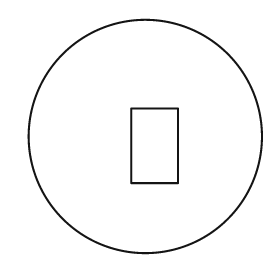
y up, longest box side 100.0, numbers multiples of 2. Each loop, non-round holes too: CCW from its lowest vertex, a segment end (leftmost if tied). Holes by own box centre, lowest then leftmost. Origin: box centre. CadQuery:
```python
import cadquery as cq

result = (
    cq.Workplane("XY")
    .moveTo(0.0, 0.0)
    .circle(50.0)
    .moveTo(-6.0, -20.0)
    .lineTo(14.0, -20.0)
    .lineTo(14.0, 12.0)
    .lineTo(-6.0, 12.0)
    .close()
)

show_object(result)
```